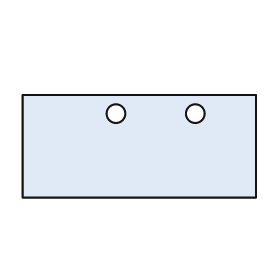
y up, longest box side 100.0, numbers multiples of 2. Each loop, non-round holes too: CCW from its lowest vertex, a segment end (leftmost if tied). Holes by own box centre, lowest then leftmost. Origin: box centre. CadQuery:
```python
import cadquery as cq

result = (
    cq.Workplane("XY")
    .moveTo(-50.0, -22.0)
    .lineTo(50.0, -22.0)
    .lineTo(50.0, 22.0)
    .lineTo(-50.0, 22.0)
    .close()
    .moveTo(-10.0, 14.0)
    .circle(4.0)
    .moveTo(24.0, 14.0)
    .circle(4.0)
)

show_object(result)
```